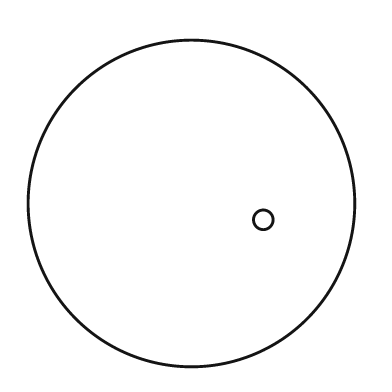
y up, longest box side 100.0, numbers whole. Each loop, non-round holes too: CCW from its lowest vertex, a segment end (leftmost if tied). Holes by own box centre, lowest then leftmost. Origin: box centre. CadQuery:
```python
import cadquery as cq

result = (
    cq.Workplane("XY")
    .moveTo(0.0, 0.0)
    .circle(50.0)
    .moveTo(22.0, -5.0)
    .circle(3.0)
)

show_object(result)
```